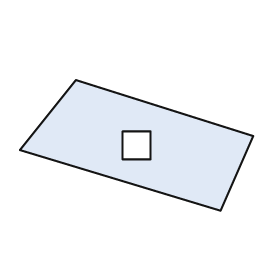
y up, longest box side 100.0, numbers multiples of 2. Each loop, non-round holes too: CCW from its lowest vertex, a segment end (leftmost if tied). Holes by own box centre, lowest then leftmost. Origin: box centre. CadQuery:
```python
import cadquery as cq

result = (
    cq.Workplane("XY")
    .moveTo(36.0, -28.0)
    .lineTo(50.0, 4.0)
    .lineTo(-26.0, 28.0)
    .lineTo(-50.0, -2.0)
    .close()
    .moveTo(-6.0, -6.0)
    .lineTo(6.0, -6.0)
    .lineTo(6.0, 6.0)
    .lineTo(-6.0, 6.0)
    .close()
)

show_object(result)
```